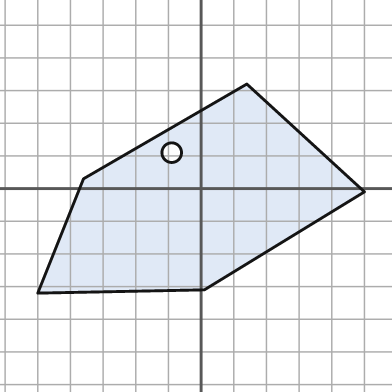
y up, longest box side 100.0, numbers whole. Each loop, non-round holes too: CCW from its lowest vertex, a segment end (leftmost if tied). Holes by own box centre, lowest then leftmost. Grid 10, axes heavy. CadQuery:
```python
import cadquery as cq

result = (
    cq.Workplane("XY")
    .moveTo(-50.0, -32.0)
    .lineTo(1.0, -31.0)
    .lineTo(50.0, -1.0)
    .lineTo(14.0, 32.0)
    .lineTo(-36.0, 3.0)
    .close()
    .moveTo(-9.0, 11.0)
    .circle(3.0)
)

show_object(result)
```